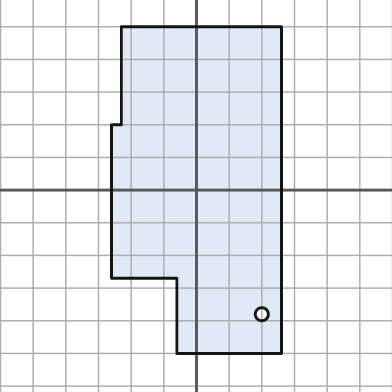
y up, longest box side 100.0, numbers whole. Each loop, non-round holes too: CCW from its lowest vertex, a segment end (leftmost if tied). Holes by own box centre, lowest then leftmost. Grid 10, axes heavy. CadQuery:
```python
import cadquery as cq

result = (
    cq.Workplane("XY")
    .moveTo(-6.0, -50.0)
    .lineTo(26.0, -50.0)
    .lineTo(26.0, 50.0)
    .lineTo(-23.0, 50.0)
    .lineTo(-23.0, 20.0)
    .lineTo(-26.0, 20.0)
    .lineTo(-26.0, -27.0)
    .lineTo(-6.0, -27.0)
    .close()
    .moveTo(20.0, -38.0)
    .circle(2.0)
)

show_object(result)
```